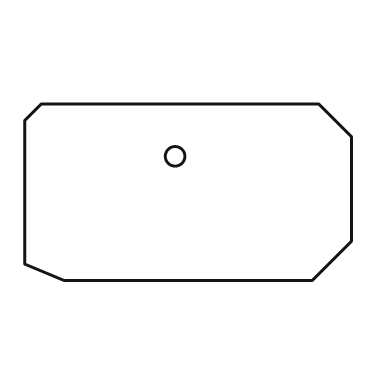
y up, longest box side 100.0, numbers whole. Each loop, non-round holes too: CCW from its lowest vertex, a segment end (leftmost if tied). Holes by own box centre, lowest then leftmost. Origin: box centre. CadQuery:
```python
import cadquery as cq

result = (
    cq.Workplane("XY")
    .moveTo(-38.0, -27.0)
    .lineTo(38.0, -27.0)
    .lineTo(50.0, -15.0)
    .lineTo(50.0, 17.0)
    .lineTo(40.0, 27.0)
    .lineTo(-45.0, 27.0)
    .lineTo(-50.0, 22.0)
    .lineTo(-50.0, -22.0)
    .close()
    .moveTo(-4.0, 11.0)
    .circle(3.0)
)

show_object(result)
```